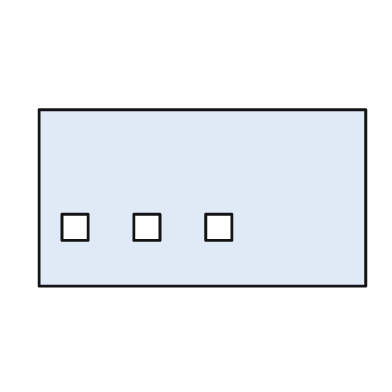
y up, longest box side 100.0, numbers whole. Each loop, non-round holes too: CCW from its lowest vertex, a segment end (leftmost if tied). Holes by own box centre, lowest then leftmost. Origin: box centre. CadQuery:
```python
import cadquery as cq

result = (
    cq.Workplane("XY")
    .moveTo(-50.0, -27.0)
    .lineTo(50.0, -27.0)
    .lineTo(50.0, 27.0)
    .lineTo(-50.0, 27.0)
    .close()
    .moveTo(-43.0, -13.0)
    .lineTo(-35.0, -13.0)
    .lineTo(-35.0, -5.0)
    .lineTo(-43.0, -5.0)
    .close()
    .moveTo(-21.0, -13.0)
    .lineTo(-13.0, -13.0)
    .lineTo(-13.0, -5.0)
    .lineTo(-21.0, -5.0)
    .close()
    .moveTo(1.0, -13.0)
    .lineTo(9.0, -13.0)
    .lineTo(9.0, -5.0)
    .lineTo(1.0, -5.0)
    .close()
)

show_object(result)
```